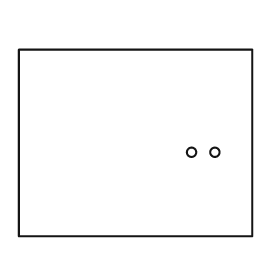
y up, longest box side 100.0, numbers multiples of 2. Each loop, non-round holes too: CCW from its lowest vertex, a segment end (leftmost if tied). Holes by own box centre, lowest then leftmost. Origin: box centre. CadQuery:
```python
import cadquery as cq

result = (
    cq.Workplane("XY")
    .moveTo(-50.0, -40.0)
    .lineTo(50.0, -40.0)
    .lineTo(50.0, 40.0)
    .lineTo(-50.0, 40.0)
    .close()
    .moveTo(24.0, -4.0)
    .circle(2.0)
    .moveTo(34.0, -4.0)
    .circle(2.0)
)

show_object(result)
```